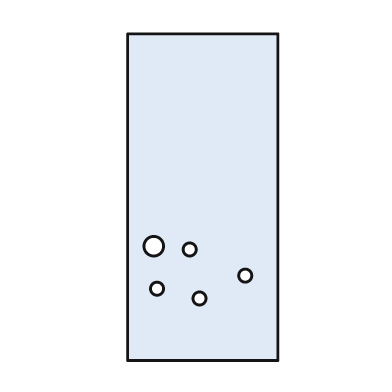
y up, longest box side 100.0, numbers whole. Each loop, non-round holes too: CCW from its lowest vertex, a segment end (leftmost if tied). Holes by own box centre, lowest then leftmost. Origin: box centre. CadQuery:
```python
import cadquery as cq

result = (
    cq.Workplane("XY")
    .moveTo(-23.0, -50.0)
    .lineTo(23.0, -50.0)
    .lineTo(23.0, 50.0)
    .lineTo(-23.0, 50.0)
    .close()
    .moveTo(-1.0, -31.0)
    .circle(2.0)
    .moveTo(-14.0, -28.0)
    .circle(2.0)
    .moveTo(13.0, -24.0)
    .circle(2.0)
    .moveTo(-4.0, -16.0)
    .circle(2.0)
    .moveTo(-15.0, -15.0)
    .circle(3.0)
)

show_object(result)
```